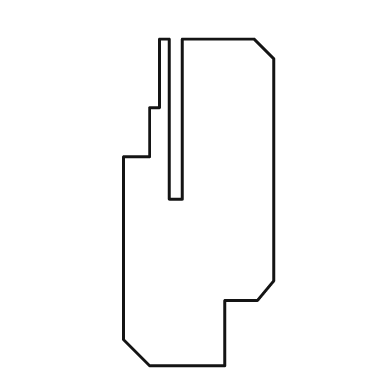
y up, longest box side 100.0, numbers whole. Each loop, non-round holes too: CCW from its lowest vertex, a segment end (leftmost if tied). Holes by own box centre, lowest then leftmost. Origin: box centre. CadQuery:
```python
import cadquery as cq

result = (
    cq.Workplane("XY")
    .moveTo(-15.0, -50.0)
    .lineTo(8.0, -50.0)
    .lineTo(8.0, -30.0)
    .lineTo(18.0, -30.0)
    .lineTo(23.0, -24.0)
    .lineTo(23.0, 44.0)
    .lineTo(17.0, 50.0)
    .lineTo(-5.0, 50.0)
    .lineTo(-5.0, 1.0)
    .lineTo(-9.0, 1.0)
    .lineTo(-9.0, 50.0)
    .lineTo(-12.0, 50.0)
    .lineTo(-12.0, 29.0)
    .lineTo(-15.0, 29.0)
    .lineTo(-15.0, 14.0)
    .lineTo(-23.0, 14.0)
    .lineTo(-23.0, -42.0)
    .close()
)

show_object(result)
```